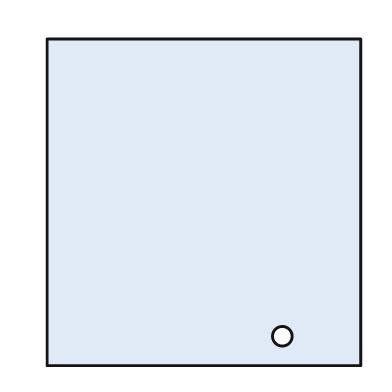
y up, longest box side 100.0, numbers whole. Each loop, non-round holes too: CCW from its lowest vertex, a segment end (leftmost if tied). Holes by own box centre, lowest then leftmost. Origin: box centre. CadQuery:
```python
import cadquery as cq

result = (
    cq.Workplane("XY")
    .moveTo(-48.0, -50.0)
    .lineTo(48.0, -50.0)
    .lineTo(48.0, 50.0)
    .lineTo(-48.0, 50.0)
    .close()
    .moveTo(24.0, -41.0)
    .circle(3.0)
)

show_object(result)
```